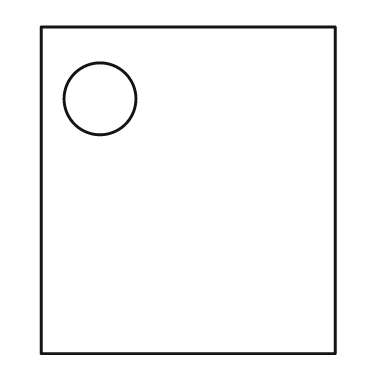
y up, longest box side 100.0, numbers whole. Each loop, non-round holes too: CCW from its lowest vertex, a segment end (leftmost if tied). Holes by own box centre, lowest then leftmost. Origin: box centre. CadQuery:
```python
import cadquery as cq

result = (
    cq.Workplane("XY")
    .moveTo(-45.0, -50.0)
    .lineTo(45.0, -50.0)
    .lineTo(45.0, 50.0)
    .lineTo(-45.0, 50.0)
    .close()
    .moveTo(-27.0, 28.0)
    .circle(11.0)
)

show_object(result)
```